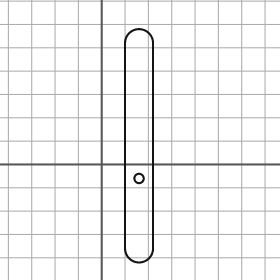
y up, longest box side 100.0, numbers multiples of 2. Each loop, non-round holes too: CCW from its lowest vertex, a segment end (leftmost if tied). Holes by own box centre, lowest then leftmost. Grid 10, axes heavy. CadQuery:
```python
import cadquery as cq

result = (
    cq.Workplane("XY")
    .moveTo(10.0, -36.0)
    .threePointArc((16.0, -42.0), (22.0, -36.0))
    .lineTo(22.0, 52.0)
    .threePointArc((16.0, 58.0), (10.0, 52.0))
    .close()
    .moveTo(16.0, -6.0)
    .circle(2.0)
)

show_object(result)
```